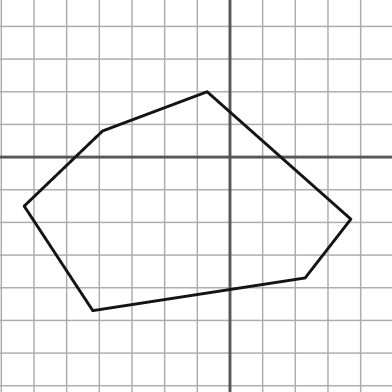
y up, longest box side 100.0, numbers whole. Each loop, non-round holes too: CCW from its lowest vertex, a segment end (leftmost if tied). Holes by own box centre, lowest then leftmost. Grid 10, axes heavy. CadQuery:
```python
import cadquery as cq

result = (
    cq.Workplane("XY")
    .moveTo(-42.0, -47.0)
    .lineTo(23.0, -37.0)
    .lineTo(37.0, -19.0)
    .lineTo(-7.0, 20.0)
    .lineTo(-39.0, 8.0)
    .lineTo(-63.0, -15.0)
    .close()
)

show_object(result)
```